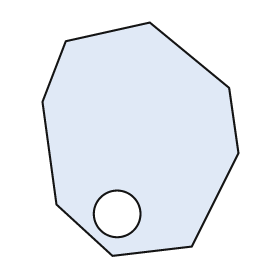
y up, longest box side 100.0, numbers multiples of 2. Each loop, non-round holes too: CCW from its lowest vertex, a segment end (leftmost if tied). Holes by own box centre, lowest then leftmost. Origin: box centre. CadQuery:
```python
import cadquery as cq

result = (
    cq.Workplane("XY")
    .moveTo(-12.0, -50.0)
    .lineTo(22.0, -46.0)
    .lineTo(42.0, -6.0)
    .lineTo(38.0, 22.0)
    .lineTo(4.0, 50.0)
    .lineTo(-32.0, 42.0)
    .lineTo(-42.0, 16.0)
    .lineTo(-36.0, -28.0)
    .close()
    .moveTo(-10.0, -32.0)
    .circle(10.0)
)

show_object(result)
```